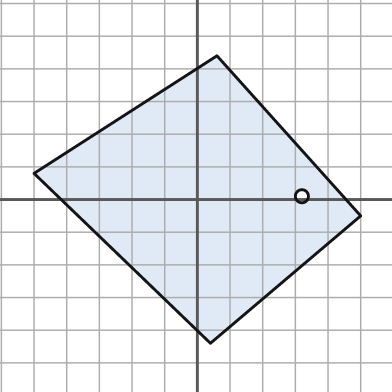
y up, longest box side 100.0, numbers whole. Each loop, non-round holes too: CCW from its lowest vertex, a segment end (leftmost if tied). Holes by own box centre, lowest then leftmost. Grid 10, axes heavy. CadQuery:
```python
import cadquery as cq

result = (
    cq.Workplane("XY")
    .moveTo(4.0, -44.0)
    .lineTo(50.0, -5.0)
    .lineTo(6.0, 44.0)
    .lineTo(-50.0, 8.0)
    .close()
    .moveTo(32.0, 1.0)
    .circle(2.0)
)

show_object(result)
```